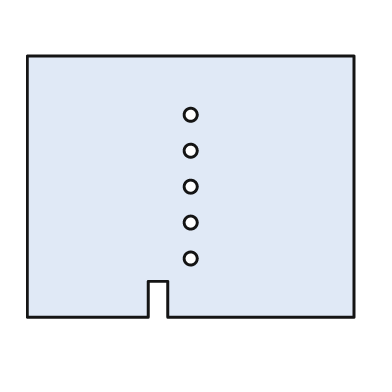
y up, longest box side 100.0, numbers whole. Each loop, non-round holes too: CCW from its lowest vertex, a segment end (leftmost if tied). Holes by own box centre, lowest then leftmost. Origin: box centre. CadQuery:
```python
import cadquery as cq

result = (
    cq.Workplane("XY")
    .moveTo(-50.0, -40.0)
    .lineTo(-13.0, -40.0)
    .lineTo(-13.0, -29.0)
    .lineTo(-7.0, -29.0)
    .lineTo(-7.0, -40.0)
    .lineTo(50.0, -40.0)
    .lineTo(50.0, 40.0)
    .lineTo(-50.0, 40.0)
    .close()
    .moveTo(0.0, -22.0)
    .circle(2.0)
    .moveTo(0.0, -11.0)
    .circle(2.0)
    .moveTo(0.0, 0.0)
    .circle(2.0)
    .moveTo(0.0, 11.0)
    .circle(2.0)
    .moveTo(0.0, 22.0)
    .circle(2.0)
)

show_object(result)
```